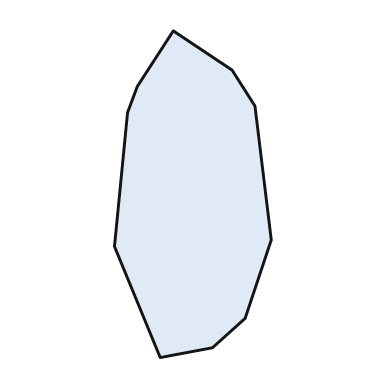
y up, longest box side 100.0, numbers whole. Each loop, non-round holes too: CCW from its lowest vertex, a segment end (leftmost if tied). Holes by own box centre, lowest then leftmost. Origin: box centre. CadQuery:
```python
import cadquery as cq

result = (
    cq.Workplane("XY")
    .moveTo(-10.0, -50.0)
    .lineTo(6.0, -47.0)
    .lineTo(16.0, -38.0)
    .lineTo(24.0, -14.0)
    .lineTo(19.0, 27.0)
    .lineTo(12.0, 38.0)
    .lineTo(-6.0, 50.0)
    .lineTo(-17.0, 33.0)
    .lineTo(-20.0, 25.0)
    .lineTo(-24.0, -16.0)
    .close()
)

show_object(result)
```